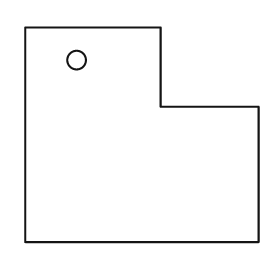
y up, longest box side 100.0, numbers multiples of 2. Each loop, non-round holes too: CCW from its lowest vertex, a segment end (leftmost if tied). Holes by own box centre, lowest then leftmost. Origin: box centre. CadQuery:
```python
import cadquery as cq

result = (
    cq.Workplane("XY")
    .moveTo(-50.0, -46.0)
    .lineTo(50.0, -46.0)
    .lineTo(50.0, 12.0)
    .lineTo(8.0, 12.0)
    .lineTo(8.0, 46.0)
    .lineTo(-50.0, 46.0)
    .close()
    .moveTo(-28.0, 32.0)
    .circle(4.0)
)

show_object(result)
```